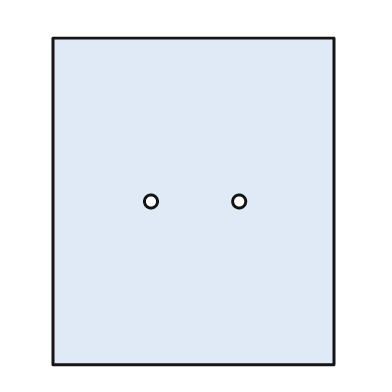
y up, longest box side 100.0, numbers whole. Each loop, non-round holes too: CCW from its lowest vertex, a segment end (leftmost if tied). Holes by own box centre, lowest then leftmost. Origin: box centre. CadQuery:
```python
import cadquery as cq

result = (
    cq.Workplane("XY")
    .moveTo(-43.0, -50.0)
    .lineTo(43.0, -50.0)
    .lineTo(43.0, 50.0)
    .lineTo(-43.0, 50.0)
    .close()
    .moveTo(-13.0, 0.0)
    .circle(2.0)
    .moveTo(14.0, 0.0)
    .circle(2.0)
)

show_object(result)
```